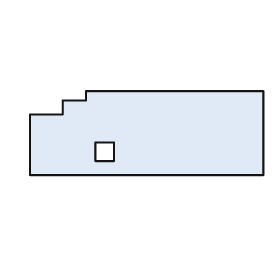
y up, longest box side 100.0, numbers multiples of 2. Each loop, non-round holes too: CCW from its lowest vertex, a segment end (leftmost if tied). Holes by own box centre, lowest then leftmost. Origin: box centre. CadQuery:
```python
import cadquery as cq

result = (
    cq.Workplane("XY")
    .moveTo(-50.0, -18.0)
    .lineTo(50.0, -18.0)
    .lineTo(50.0, 18.0)
    .lineTo(-26.0, 18.0)
    .lineTo(-26.0, 14.0)
    .lineTo(-36.0, 14.0)
    .lineTo(-36.0, 8.0)
    .lineTo(-50.0, 8.0)
    .close()
    .moveTo(-22.0, -12.0)
    .lineTo(-14.0, -12.0)
    .lineTo(-14.0, -4.0)
    .lineTo(-22.0, -4.0)
    .close()
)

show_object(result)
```